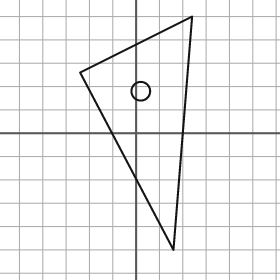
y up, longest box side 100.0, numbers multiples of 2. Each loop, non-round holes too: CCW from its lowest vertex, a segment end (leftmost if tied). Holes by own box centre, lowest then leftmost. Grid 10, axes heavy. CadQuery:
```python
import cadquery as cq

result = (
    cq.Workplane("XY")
    .moveTo(16.0, -50.0)
    .lineTo(24.0, 50.0)
    .lineTo(-24.0, 26.0)
    .close()
    .moveTo(2.0, 18.0)
    .circle(4.0)
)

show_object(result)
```